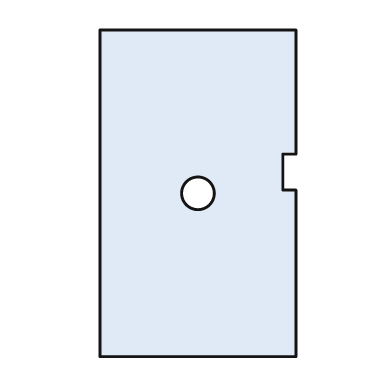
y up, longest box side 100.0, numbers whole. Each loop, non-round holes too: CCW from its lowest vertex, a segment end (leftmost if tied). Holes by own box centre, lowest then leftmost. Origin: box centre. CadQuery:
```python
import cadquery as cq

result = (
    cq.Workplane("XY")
    .moveTo(-30.0, -50.0)
    .lineTo(30.0, -50.0)
    .lineTo(30.0, 1.0)
    .lineTo(26.0, 1.0)
    .lineTo(26.0, 12.0)
    .lineTo(30.0, 12.0)
    .lineTo(30.0, 50.0)
    .lineTo(-30.0, 50.0)
    .close()
    .moveTo(0.0, 0.0)
    .circle(5.0)
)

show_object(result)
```